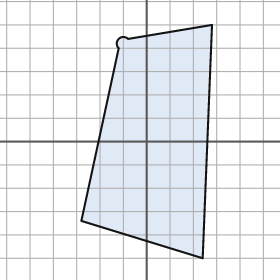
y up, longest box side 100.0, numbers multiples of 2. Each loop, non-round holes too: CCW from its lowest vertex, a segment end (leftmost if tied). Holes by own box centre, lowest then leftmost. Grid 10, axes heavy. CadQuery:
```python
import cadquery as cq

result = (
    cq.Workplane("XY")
    .moveTo(24.0, -50.0)
    .lineTo(28.0, 50.0)
    .lineTo(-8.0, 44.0)
    .threePointArc((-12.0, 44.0), (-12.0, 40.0))
    .lineTo(-28.0, -34.0)
    .close()
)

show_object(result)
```